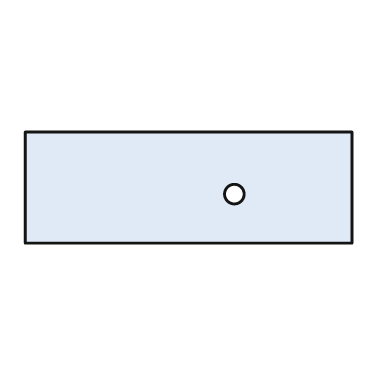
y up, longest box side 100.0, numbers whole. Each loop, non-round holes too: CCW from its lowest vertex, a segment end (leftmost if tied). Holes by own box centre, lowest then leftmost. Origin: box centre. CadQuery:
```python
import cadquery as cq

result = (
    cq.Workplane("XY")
    .moveTo(-50.0, -17.0)
    .lineTo(50.0, -17.0)
    .lineTo(50.0, 17.0)
    .lineTo(-50.0, 17.0)
    .close()
    .moveTo(14.0, -2.0)
    .circle(3.0)
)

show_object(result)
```